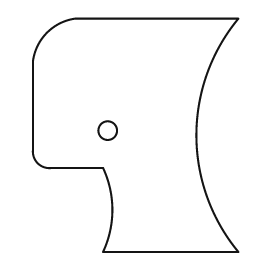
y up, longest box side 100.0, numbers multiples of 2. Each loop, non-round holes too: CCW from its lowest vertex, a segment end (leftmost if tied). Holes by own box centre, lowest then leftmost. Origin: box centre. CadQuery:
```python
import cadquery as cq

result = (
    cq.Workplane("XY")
    .moveTo(-14.0, -50.0)
    .lineTo(44.0, -50.0)
    .threePointArc((26.0, 0.0), (44.0, 50.0))
    .lineTo(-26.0, 50.0)
    .threePointArc((-38.0, 44.0), (-44.0, 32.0))
    .lineTo(-44.0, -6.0)
    .threePointArc((-42.0, -12.0), (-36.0, -14.0))
    .lineTo(-14.0, -14.0)
    .threePointArc((-10.0, -32.0), (-14.0, -50.0))
    .close()
    .moveTo(-12.0, 2.0)
    .circle(4.0)
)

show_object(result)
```